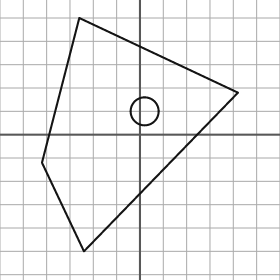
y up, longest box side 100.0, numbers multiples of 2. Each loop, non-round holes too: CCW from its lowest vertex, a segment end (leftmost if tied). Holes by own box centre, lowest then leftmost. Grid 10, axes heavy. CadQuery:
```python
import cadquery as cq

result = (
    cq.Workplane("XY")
    .moveTo(-24.0, -50.0)
    .lineTo(42.0, 18.0)
    .lineTo(-26.0, 50.0)
    .lineTo(-42.0, -12.0)
    .close()
    .moveTo(2.0, 10.0)
    .circle(6.0)
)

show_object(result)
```